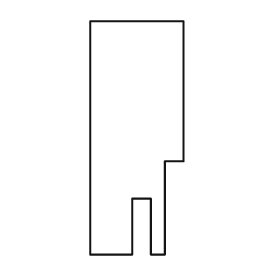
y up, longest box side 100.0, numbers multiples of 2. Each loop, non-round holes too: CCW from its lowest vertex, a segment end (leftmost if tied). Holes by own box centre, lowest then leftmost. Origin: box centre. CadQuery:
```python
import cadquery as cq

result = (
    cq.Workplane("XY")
    .moveTo(-20.0, -50.0)
    .lineTo(-2.0, -50.0)
    .lineTo(-2.0, -26.0)
    .lineTo(6.0, -26.0)
    .lineTo(6.0, -50.0)
    .lineTo(12.0, -50.0)
    .lineTo(12.0, -10.0)
    .lineTo(20.0, -10.0)
    .lineTo(20.0, 50.0)
    .lineTo(-20.0, 50.0)
    .close()
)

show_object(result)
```